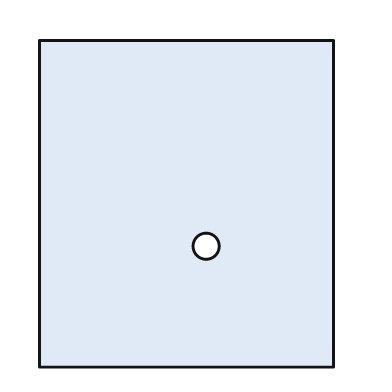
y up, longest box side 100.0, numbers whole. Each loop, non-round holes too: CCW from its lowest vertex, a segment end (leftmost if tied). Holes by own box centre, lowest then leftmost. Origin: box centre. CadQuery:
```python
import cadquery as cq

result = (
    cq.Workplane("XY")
    .moveTo(-45.0, -50.0)
    .lineTo(45.0, -50.0)
    .lineTo(45.0, 50.0)
    .lineTo(-45.0, 50.0)
    .close()
    .moveTo(6.0, -13.0)
    .circle(4.0)
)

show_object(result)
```